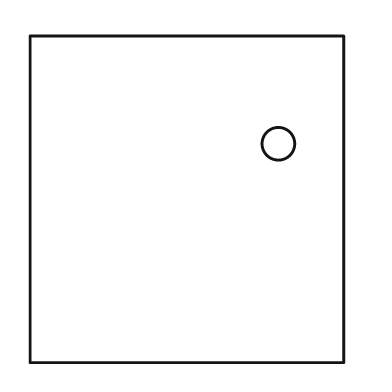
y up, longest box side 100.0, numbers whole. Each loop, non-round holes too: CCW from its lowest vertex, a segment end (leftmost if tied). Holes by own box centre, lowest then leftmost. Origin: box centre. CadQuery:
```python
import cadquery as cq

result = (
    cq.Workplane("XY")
    .moveTo(-48.0, -50.0)
    .lineTo(48.0, -50.0)
    .lineTo(48.0, 50.0)
    .lineTo(-48.0, 50.0)
    .close()
    .moveTo(28.0, 17.0)
    .circle(5.0)
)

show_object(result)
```